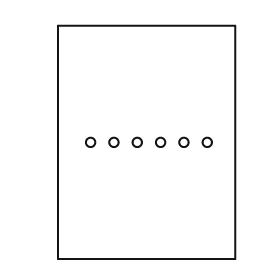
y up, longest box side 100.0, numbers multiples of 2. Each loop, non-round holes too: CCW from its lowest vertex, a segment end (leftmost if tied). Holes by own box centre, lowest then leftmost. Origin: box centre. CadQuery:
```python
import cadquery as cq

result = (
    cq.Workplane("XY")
    .moveTo(-38.0, -50.0)
    .lineTo(38.0, -50.0)
    .lineTo(38.0, 50.0)
    .lineTo(-38.0, 50.0)
    .close()
    .moveTo(-24.0, 0.0)
    .circle(2.0)
    .moveTo(-14.0, 0.0)
    .circle(2.0)
    .moveTo(-4.0, 0.0)
    .circle(2.0)
    .moveTo(6.0, 0.0)
    .circle(2.0)
    .moveTo(16.0, 0.0)
    .circle(2.0)
    .moveTo(26.0, 0.0)
    .circle(2.0)
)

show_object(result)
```